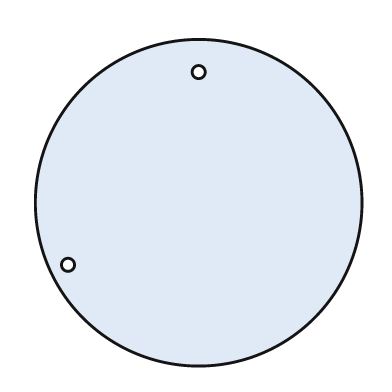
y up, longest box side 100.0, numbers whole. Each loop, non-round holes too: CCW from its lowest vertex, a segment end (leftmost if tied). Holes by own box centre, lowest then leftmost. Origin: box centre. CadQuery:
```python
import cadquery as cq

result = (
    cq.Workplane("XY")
    .moveTo(0.0, 0.0)
    .circle(50.0)
    .moveTo(-40.0, -19.0)
    .circle(2.0)
    .moveTo(0.0, 40.0)
    .circle(2.0)
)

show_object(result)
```